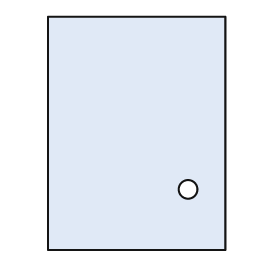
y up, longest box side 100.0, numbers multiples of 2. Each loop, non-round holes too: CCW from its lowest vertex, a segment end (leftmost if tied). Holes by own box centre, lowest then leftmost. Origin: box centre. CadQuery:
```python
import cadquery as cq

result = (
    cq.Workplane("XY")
    .moveTo(-38.0, -50.0)
    .lineTo(38.0, -50.0)
    .lineTo(38.0, 50.0)
    .lineTo(-38.0, 50.0)
    .close()
    .moveTo(22.0, -24.0)
    .circle(4.0)
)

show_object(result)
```